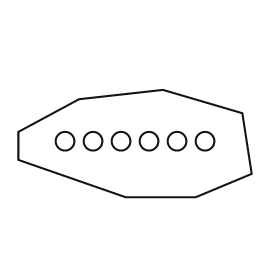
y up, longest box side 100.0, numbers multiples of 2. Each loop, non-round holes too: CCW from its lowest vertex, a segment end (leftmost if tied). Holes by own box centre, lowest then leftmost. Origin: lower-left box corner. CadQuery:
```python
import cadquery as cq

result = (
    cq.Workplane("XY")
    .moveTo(46.0, 0.0)
    .lineTo(76.0, 0.0)
    .lineTo(100.0, 10.0)
    .lineTo(96.0, 36.0)
    .lineTo(62.0, 46.0)
    .lineTo(26.0, 42.0)
    .lineTo(0.0, 28.0)
    .lineTo(0.0, 16.0)
    .close()
    .moveTo(20.0, 24.0)
    .circle(4.0)
    .moveTo(32.0, 24.0)
    .circle(4.0)
    .moveTo(44.0, 24.0)
    .circle(4.0)
    .moveTo(56.0, 24.0)
    .circle(4.0)
    .moveTo(68.0, 24.0)
    .circle(4.0)
    .moveTo(80.0, 24.0)
    .circle(4.0)
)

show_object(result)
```